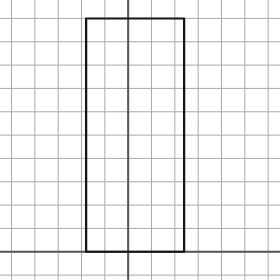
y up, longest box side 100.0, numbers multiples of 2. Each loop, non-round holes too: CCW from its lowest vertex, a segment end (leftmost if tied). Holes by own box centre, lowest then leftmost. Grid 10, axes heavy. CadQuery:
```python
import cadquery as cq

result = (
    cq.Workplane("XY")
    .moveTo(-18.0, 0.0)
    .lineTo(24.0, 0.0)
    .lineTo(24.0, 100.0)
    .lineTo(-18.0, 100.0)
    .close()
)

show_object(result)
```